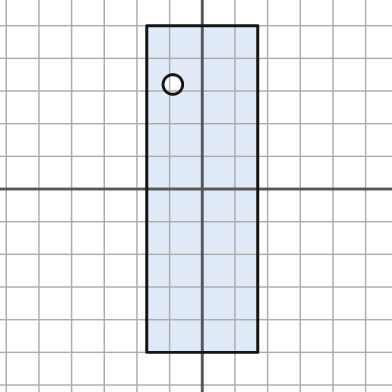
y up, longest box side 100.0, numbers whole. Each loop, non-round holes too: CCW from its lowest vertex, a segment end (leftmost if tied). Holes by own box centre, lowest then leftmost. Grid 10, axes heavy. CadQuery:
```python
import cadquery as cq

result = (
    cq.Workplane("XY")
    .moveTo(-17.0, -50.0)
    .lineTo(17.0, -50.0)
    .lineTo(17.0, 50.0)
    .lineTo(-17.0, 50.0)
    .close()
    .moveTo(-9.0, 32.0)
    .circle(3.0)
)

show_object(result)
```